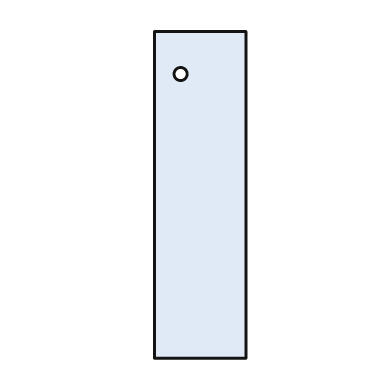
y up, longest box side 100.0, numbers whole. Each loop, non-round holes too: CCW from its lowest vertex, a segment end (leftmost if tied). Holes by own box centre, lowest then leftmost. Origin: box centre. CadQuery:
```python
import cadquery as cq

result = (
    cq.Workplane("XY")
    .moveTo(-14.0, -50.0)
    .lineTo(14.0, -50.0)
    .lineTo(14.0, 50.0)
    .lineTo(-14.0, 50.0)
    .close()
    .moveTo(-6.0, 37.0)
    .circle(2.0)
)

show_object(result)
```